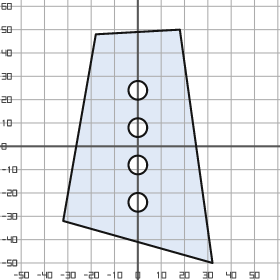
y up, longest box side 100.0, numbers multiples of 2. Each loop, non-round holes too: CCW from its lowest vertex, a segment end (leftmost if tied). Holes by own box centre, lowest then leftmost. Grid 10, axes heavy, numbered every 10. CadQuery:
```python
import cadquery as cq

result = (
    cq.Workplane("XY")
    .moveTo(32.0, -50.0)
    .lineTo(18.0, 50.0)
    .lineTo(-18.0, 48.0)
    .lineTo(-32.0, -32.0)
    .close()
    .moveTo(0.0, -24.0)
    .circle(4.0)
    .moveTo(0.0, -8.0)
    .circle(4.0)
    .moveTo(0.0, 8.0)
    .circle(4.0)
    .moveTo(0.0, 24.0)
    .circle(4.0)
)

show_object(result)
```